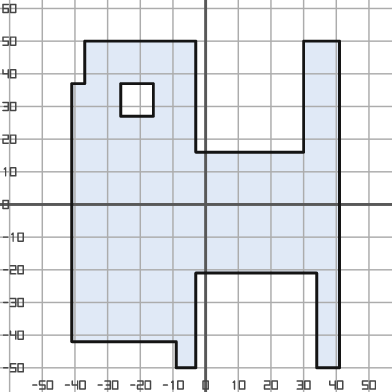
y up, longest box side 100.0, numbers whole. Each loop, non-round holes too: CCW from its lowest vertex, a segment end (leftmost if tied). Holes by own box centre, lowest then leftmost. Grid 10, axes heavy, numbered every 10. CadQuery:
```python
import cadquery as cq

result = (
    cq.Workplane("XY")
    .moveTo(-9.0, -50.0)
    .lineTo(-3.0, -50.0)
    .lineTo(-3.0, -21.0)
    .lineTo(34.0, -21.0)
    .lineTo(34.0, -50.0)
    .lineTo(41.0, -50.0)
    .lineTo(41.0, 50.0)
    .lineTo(30.0, 50.0)
    .lineTo(30.0, 16.0)
    .lineTo(-3.0, 16.0)
    .lineTo(-3.0, 50.0)
    .lineTo(-37.0, 50.0)
    .lineTo(-37.0, 37.0)
    .lineTo(-41.0, 37.0)
    .lineTo(-41.0, -42.0)
    .lineTo(-9.0, -42.0)
    .close()
    .moveTo(-26.0, 27.0)
    .lineTo(-16.0, 27.0)
    .lineTo(-16.0, 37.0)
    .lineTo(-26.0, 37.0)
    .close()
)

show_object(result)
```